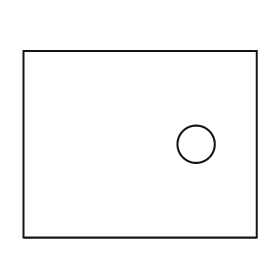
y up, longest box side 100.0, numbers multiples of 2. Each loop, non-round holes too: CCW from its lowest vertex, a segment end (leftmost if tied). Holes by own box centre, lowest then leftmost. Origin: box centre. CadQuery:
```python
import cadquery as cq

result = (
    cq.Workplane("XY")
    .moveTo(-50.0, -40.0)
    .lineTo(50.0, -40.0)
    .lineTo(50.0, 40.0)
    .lineTo(-50.0, 40.0)
    .close()
    .moveTo(24.0, 0.0)
    .circle(8.0)
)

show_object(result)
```